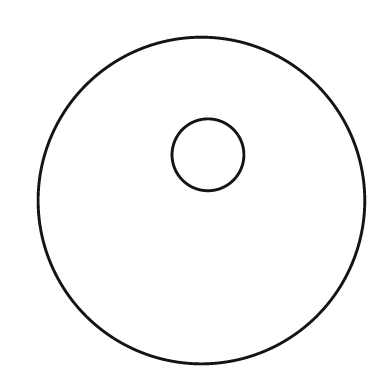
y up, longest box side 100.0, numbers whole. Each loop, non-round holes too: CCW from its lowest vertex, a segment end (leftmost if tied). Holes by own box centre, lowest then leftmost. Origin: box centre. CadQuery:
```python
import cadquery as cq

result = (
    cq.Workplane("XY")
    .moveTo(0.0, 0.0)
    .circle(50.0)
    .moveTo(2.0, 14.0)
    .circle(11.0)
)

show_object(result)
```